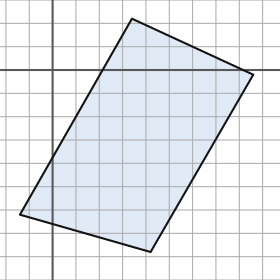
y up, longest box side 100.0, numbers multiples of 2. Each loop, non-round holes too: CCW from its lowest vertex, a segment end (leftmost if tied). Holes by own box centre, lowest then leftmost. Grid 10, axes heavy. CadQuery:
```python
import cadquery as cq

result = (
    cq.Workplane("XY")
    .moveTo(42.0, -78.0)
    .lineTo(86.0, -2.0)
    .lineTo(34.0, 22.0)
    .lineTo(-14.0, -62.0)
    .close()
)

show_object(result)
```